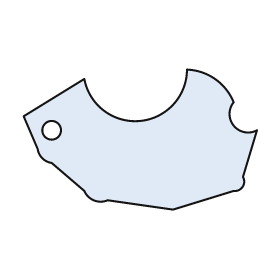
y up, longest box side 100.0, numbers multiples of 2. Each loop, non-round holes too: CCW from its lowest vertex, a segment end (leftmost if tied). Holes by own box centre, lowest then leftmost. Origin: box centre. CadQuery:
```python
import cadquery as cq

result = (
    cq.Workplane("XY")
    .moveTo(14.0, -30.0)
    .lineTo(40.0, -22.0)
    .threePointArc((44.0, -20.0), (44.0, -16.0))
    .lineTo(50.0, 4.0)
    .threePointArc((40.0, 6.0), (40.0, 16.0))
    .threePointArc((32.0, 26.0), (20.0, 30.0))
    .threePointArc((0.0, 8.0), (-24.0, 26.0))
    .lineTo(-50.0, 10.0)
    .lineTo(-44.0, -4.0)
    .threePointArc((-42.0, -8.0), (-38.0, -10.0))
    .lineTo(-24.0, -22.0)
    .threePointArc((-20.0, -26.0), (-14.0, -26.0))
    .close()
    .moveTo(-38.0, 4.0)
    .circle(4.0)
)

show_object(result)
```